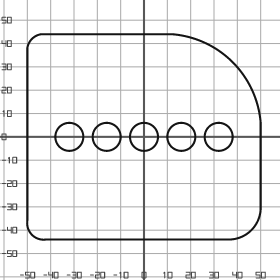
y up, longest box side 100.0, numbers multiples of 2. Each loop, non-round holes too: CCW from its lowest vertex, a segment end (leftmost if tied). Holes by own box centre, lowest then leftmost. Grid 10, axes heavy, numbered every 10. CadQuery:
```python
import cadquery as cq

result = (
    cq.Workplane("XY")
    .moveTo(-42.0, -44.0)
    .lineTo(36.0, -44.0)
    .threePointArc((46.0, -40.0), (50.0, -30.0))
    .lineTo(50.0, 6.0)
    .threePointArc((38.0, 32.0), (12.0, 44.0))
    .lineTo(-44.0, 44.0)
    .threePointArc((-48.0, 42.0), (-50.0, 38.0))
    .lineTo(-50.0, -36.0)
    .threePointArc((-48.0, -42.0), (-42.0, -44.0))
    .close()
    .moveTo(-32.0, 0.0)
    .circle(6.0)
    .moveTo(-16.0, 0.0)
    .circle(6.0)
    .moveTo(0.0, 0.0)
    .circle(6.0)
    .moveTo(16.0, 0.0)
    .circle(6.0)
    .moveTo(32.0, 0.0)
    .circle(6.0)
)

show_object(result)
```